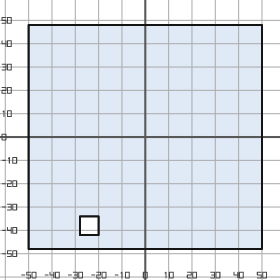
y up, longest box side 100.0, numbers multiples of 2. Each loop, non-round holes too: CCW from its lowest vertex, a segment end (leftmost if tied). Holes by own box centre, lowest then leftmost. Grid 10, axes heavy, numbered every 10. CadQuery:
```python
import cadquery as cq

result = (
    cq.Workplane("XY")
    .moveTo(-50.0, -48.0)
    .lineTo(50.0, -48.0)
    .lineTo(50.0, 48.0)
    .lineTo(-50.0, 48.0)
    .close()
    .moveTo(-28.0, -42.0)
    .lineTo(-20.0, -42.0)
    .lineTo(-20.0, -34.0)
    .lineTo(-28.0, -34.0)
    .close()
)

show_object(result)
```